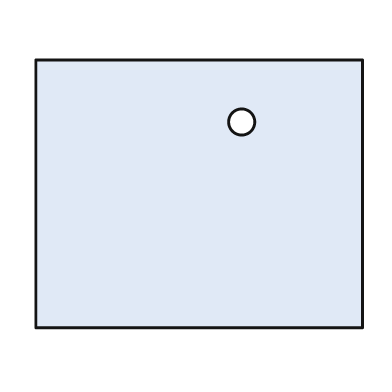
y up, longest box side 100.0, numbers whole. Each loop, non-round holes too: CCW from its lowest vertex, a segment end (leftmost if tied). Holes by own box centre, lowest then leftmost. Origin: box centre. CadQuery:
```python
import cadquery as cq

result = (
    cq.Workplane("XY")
    .moveTo(-50.0, -41.0)
    .lineTo(50.0, -41.0)
    .lineTo(50.0, 41.0)
    .lineTo(-50.0, 41.0)
    .close()
    .moveTo(13.0, 22.0)
    .circle(4.0)
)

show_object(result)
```